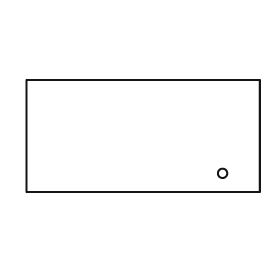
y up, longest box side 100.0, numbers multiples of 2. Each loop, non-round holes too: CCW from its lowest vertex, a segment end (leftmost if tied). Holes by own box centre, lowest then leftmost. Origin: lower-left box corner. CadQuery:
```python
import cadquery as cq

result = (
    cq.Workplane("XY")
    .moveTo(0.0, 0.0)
    .lineTo(100.0, 0.0)
    .lineTo(100.0, 48.0)
    .lineTo(0.0, 48.0)
    .close()
    .moveTo(84.0, 8.0)
    .circle(2.0)
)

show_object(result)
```